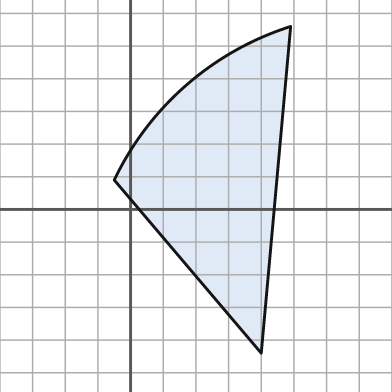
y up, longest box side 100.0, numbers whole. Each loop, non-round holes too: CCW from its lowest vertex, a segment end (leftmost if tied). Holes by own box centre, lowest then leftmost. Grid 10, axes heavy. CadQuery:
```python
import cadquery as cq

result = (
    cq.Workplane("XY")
    .moveTo(40.0, -44.0)
    .lineTo(49.0, 56.0)
    .threePointArc((17.0, 38.0), (-5.0, 9.0))
    .close()
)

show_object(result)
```